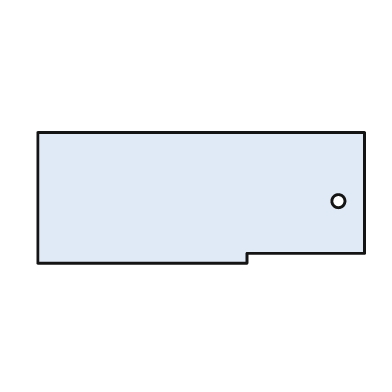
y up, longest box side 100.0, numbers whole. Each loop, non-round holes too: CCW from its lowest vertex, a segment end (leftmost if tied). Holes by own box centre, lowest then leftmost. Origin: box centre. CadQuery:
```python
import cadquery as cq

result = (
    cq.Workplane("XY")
    .moveTo(-50.0, -20.0)
    .lineTo(14.0, -20.0)
    .lineTo(14.0, -17.0)
    .lineTo(50.0, -17.0)
    .lineTo(50.0, 20.0)
    .lineTo(-50.0, 20.0)
    .close()
    .moveTo(42.0, -1.0)
    .circle(2.0)
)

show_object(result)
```